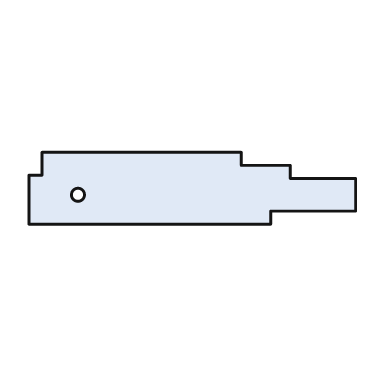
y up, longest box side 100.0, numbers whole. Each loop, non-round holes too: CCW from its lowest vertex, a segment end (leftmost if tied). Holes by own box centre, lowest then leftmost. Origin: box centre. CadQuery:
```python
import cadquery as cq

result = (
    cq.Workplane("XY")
    .moveTo(-50.0, -11.0)
    .lineTo(24.0, -11.0)
    .lineTo(24.0, -7.0)
    .lineTo(50.0, -7.0)
    .lineTo(50.0, 3.0)
    .lineTo(30.0, 3.0)
    .lineTo(30.0, 7.0)
    .lineTo(15.0, 7.0)
    .lineTo(15.0, 11.0)
    .lineTo(-46.0, 11.0)
    .lineTo(-46.0, 4.0)
    .lineTo(-50.0, 4.0)
    .close()
    .moveTo(-35.0, -2.0)
    .circle(2.0)
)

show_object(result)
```